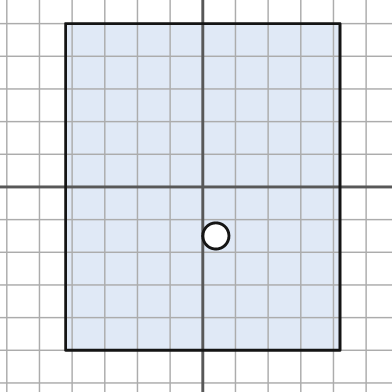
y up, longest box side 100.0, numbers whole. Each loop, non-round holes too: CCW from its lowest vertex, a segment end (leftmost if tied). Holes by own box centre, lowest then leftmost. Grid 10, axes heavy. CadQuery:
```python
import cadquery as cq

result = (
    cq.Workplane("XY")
    .moveTo(-42.0, -50.0)
    .lineTo(42.0, -50.0)
    .lineTo(42.0, 50.0)
    .lineTo(-42.0, 50.0)
    .close()
    .moveTo(4.0, -15.0)
    .circle(4.0)
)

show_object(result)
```